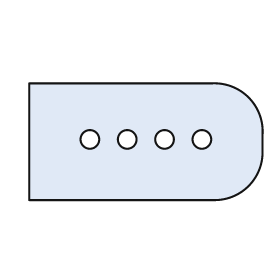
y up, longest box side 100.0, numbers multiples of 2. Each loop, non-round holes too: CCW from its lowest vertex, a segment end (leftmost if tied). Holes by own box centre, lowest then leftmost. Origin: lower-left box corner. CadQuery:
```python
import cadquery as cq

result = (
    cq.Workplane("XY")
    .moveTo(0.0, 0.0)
    .lineTo(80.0, 0.0)
    .threePointArc((94.0, 6.0), (100.0, 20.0))
    .lineTo(100.0, 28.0)
    .threePointArc((94.0, 44.0), (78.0, 50.0))
    .lineTo(0.0, 50.0)
    .close()
    .moveTo(26.0, 26.0)
    .circle(4.0)
    .moveTo(42.0, 26.0)
    .circle(4.0)
    .moveTo(58.0, 26.0)
    .circle(4.0)
    .moveTo(74.0, 26.0)
    .circle(4.0)
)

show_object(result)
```